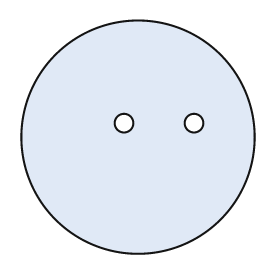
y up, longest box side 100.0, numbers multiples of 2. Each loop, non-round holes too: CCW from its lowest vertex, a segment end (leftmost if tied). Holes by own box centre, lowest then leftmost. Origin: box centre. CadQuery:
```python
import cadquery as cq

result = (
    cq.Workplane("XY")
    .moveTo(0.0, 0.0)
    .circle(50.0)
    .moveTo(-6.0, 6.0)
    .circle(4.0)
    .moveTo(24.0, 6.0)
    .circle(4.0)
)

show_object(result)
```